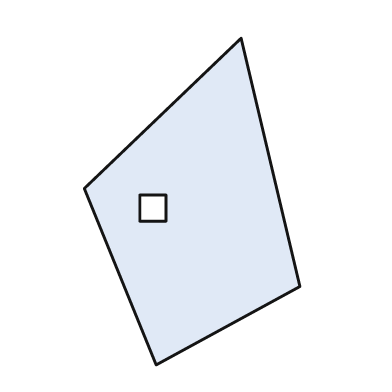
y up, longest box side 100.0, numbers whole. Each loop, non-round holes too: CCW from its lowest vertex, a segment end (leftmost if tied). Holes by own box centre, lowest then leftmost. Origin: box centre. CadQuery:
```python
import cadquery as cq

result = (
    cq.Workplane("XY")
    .moveTo(-11.0, -50.0)
    .lineTo(33.0, -26.0)
    .lineTo(15.0, 50.0)
    .lineTo(-33.0, 4.0)
    .close()
    .moveTo(-16.0, -6.0)
    .lineTo(-8.0, -6.0)
    .lineTo(-8.0, 2.0)
    .lineTo(-16.0, 2.0)
    .close()
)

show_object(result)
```